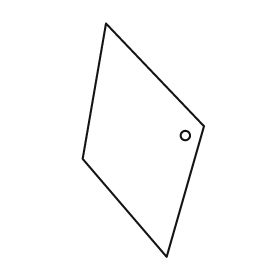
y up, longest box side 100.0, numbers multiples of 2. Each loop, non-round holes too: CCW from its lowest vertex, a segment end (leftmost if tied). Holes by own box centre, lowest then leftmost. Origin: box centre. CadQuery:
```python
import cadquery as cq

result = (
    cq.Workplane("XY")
    .moveTo(10.0, -50.0)
    .lineTo(26.0, 6.0)
    .lineTo(-16.0, 50.0)
    .lineTo(-26.0, -8.0)
    .close()
    .moveTo(18.0, 2.0)
    .circle(2.0)
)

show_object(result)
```